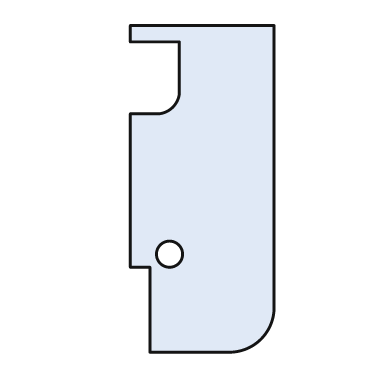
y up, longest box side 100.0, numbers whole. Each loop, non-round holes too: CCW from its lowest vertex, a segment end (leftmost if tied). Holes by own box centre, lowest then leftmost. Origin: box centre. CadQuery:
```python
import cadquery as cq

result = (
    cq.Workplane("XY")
    .moveTo(-16.0, -50.0)
    .lineTo(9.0, -50.0)
    .threePointArc((18.0, -46.0), (22.0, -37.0))
    .lineTo(22.0, 50.0)
    .lineTo(-22.0, 50.0)
    .lineTo(-22.0, 45.0)
    .lineTo(-7.0, 45.0)
    .lineTo(-7.0, 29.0)
    .threePointArc((-9.0, 25.0), (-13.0, 23.0))
    .lineTo(-22.0, 23.0)
    .lineTo(-22.0, -24.0)
    .lineTo(-16.0, -24.0)
    .close()
    .moveTo(-10.0, -20.0)
    .circle(4.0)
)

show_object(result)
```